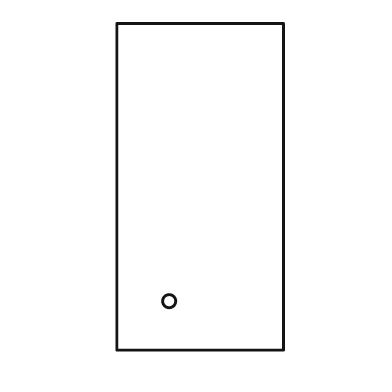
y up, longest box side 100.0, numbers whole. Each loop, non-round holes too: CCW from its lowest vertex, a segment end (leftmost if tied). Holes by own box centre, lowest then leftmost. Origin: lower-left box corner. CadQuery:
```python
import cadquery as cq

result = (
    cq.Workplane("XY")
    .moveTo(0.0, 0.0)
    .lineTo(51.0, 0.0)
    .lineTo(51.0, 100.0)
    .lineTo(0.0, 100.0)
    .close()
    .moveTo(16.0, 15.0)
    .circle(2.0)
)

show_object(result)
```